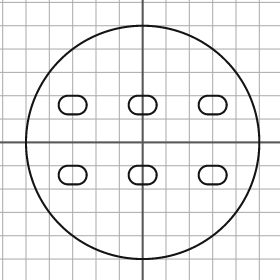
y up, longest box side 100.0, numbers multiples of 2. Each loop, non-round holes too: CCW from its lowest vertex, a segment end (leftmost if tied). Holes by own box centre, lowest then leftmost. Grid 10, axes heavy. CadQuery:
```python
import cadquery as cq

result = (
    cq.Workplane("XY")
    .moveTo(0.0, 0.0)
    .circle(50.0)
    .moveTo(-32.0, -18.0)
    .lineTo(-28.0, -18.0)
    .threePointArc((-24.0, -14.0), (-28.0, -10.0))
    .lineTo(-32.0, -10.0)
    .threePointArc((-36.0, -14.0), (-32.0, -18.0))
    .close()
    .moveTo(-2.0, -18.0)
    .lineTo(2.0, -18.0)
    .threePointArc((6.0, -14.0), (2.0, -10.0))
    .lineTo(-2.0, -10.0)
    .threePointArc((-6.0, -14.0), (-2.0, -18.0))
    .close()
    .moveTo(28.0, -18.0)
    .lineTo(32.0, -18.0)
    .threePointArc((36.0, -14.0), (32.0, -10.0))
    .lineTo(28.0, -10.0)
    .threePointArc((24.0, -14.0), (28.0, -18.0))
    .close()
    .moveTo(-32.0, 12.0)
    .lineTo(-28.0, 12.0)
    .threePointArc((-24.0, 16.0), (-28.0, 20.0))
    .lineTo(-32.0, 20.0)
    .threePointArc((-36.0, 16.0), (-32.0, 12.0))
    .close()
    .moveTo(-2.0, 12.0)
    .lineTo(2.0, 12.0)
    .threePointArc((6.0, 16.0), (2.0, 20.0))
    .lineTo(-2.0, 20.0)
    .threePointArc((-6.0, 16.0), (-2.0, 12.0))
    .close()
    .moveTo(28.0, 12.0)
    .lineTo(32.0, 12.0)
    .threePointArc((36.0, 16.0), (32.0, 20.0))
    .lineTo(28.0, 20.0)
    .threePointArc((24.0, 16.0), (28.0, 12.0))
    .close()
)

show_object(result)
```